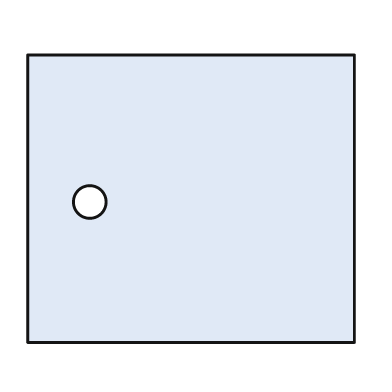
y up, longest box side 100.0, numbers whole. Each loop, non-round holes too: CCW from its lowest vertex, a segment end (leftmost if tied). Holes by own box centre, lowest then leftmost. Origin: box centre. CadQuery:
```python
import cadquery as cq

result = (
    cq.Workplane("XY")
    .moveTo(-50.0, -44.0)
    .lineTo(50.0, -44.0)
    .lineTo(50.0, 44.0)
    .lineTo(-50.0, 44.0)
    .close()
    .moveTo(-31.0, -1.0)
    .circle(5.0)
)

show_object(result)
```